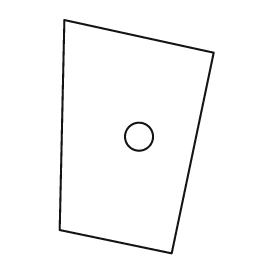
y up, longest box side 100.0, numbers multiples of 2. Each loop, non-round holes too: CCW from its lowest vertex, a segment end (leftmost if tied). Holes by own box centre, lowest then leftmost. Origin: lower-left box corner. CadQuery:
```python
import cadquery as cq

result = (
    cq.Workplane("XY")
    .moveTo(48.0, 0.0)
    .lineTo(66.0, 86.0)
    .lineTo(2.0, 100.0)
    .lineTo(0.0, 10.0)
    .close()
    .moveTo(34.0, 50.0)
    .circle(6.0)
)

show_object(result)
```